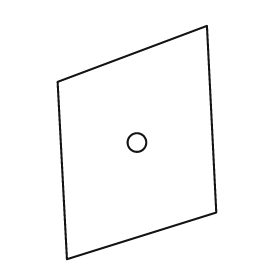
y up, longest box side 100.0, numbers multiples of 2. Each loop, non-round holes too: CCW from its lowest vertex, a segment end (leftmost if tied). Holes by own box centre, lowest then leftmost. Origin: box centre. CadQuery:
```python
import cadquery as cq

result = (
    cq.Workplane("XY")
    .moveTo(-30.0, -50.0)
    .lineTo(34.0, -30.0)
    .lineTo(30.0, 50.0)
    .lineTo(-34.0, 26.0)
    .close()
    .moveTo(0.0, 0.0)
    .circle(4.0)
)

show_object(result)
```